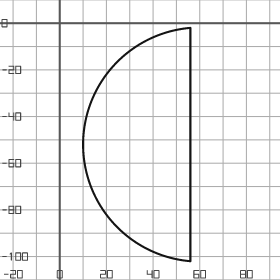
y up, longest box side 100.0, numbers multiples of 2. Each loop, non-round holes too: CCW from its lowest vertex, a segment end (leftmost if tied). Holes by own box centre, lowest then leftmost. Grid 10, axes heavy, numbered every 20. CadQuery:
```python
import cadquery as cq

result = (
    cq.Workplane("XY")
    .moveTo(56.0, -102.0)
    .lineTo(56.0, -2.0)
    .threePointArc((10.0, -52.0), (56.0, -102.0))
    .close()
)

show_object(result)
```